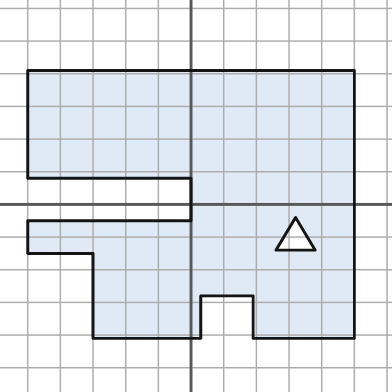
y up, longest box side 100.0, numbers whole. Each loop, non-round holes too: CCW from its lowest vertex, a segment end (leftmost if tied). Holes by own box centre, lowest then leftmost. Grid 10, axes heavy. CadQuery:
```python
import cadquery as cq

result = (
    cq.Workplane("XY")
    .moveTo(-30.0, -41.0)
    .lineTo(3.0, -41.0)
    .lineTo(3.0, -28.0)
    .lineTo(19.0, -28.0)
    .lineTo(19.0, -41.0)
    .lineTo(50.0, -41.0)
    .lineTo(50.0, 41.0)
    .lineTo(-50.0, 41.0)
    .lineTo(-50.0, 8.0)
    .lineTo(0.0, 8.0)
    .lineTo(0.0, -5.0)
    .lineTo(-50.0, -5.0)
    .lineTo(-50.0, -15.0)
    .lineTo(-30.0, -15.0)
    .close()
    .moveTo(26.0, -14.0)
    .lineTo(38.0, -14.0)
    .lineTo(32.0, -4.0)
    .close()
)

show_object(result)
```